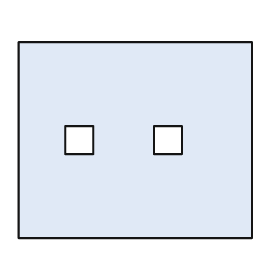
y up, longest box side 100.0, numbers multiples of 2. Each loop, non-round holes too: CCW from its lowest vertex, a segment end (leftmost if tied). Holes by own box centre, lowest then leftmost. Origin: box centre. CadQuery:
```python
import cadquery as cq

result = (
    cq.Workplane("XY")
    .moveTo(-50.0, -42.0)
    .lineTo(50.0, -42.0)
    .lineTo(50.0, 42.0)
    .lineTo(-50.0, 42.0)
    .close()
    .moveTo(-30.0, -6.0)
    .lineTo(-18.0, -6.0)
    .lineTo(-18.0, 6.0)
    .lineTo(-30.0, 6.0)
    .close()
    .moveTo(8.0, -6.0)
    .lineTo(20.0, -6.0)
    .lineTo(20.0, 6.0)
    .lineTo(8.0, 6.0)
    .close()
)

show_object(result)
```